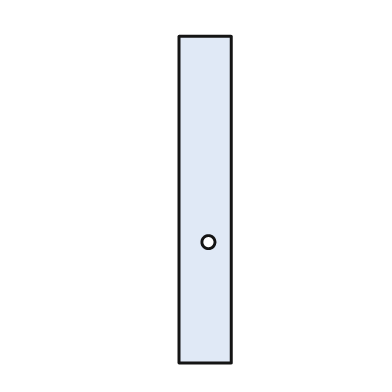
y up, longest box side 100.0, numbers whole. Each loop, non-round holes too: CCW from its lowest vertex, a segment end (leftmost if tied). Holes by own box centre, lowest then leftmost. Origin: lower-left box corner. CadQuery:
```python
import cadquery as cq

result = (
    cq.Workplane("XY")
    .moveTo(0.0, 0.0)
    .lineTo(16.0, 0.0)
    .lineTo(16.0, 100.0)
    .lineTo(0.0, 100.0)
    .close()
    .moveTo(9.0, 37.0)
    .circle(2.0)
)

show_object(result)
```